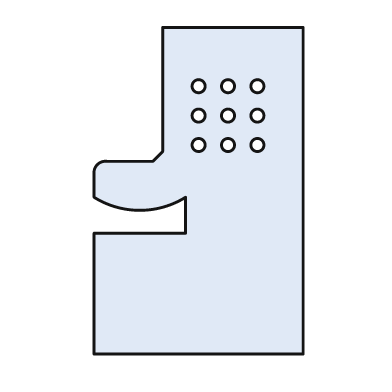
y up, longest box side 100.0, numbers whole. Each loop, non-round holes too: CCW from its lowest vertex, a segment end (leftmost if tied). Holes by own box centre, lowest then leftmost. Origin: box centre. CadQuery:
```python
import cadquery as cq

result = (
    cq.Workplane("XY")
    .moveTo(-32.0, -50.0)
    .lineTo(32.0, -50.0)
    .lineTo(32.0, 50.0)
    .lineTo(-11.0, 50.0)
    .lineTo(-11.0, 12.0)
    .lineTo(-14.0, 9.0)
    .lineTo(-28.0, 9.0)
    .threePointArc((-31.0, 8.0), (-32.0, 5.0))
    .lineTo(-32.0, -2.0)
    .threePointArc((-18.0, -6.0), (-4.0, -2.0))
    .lineTo(-4.0, -13.0)
    .lineTo(-32.0, -13.0)
    .close()
    .moveTo(0.0, 14.0)
    .circle(2.0)
    .moveTo(9.0, 14.0)
    .circle(2.0)
    .moveTo(18.0, 14.0)
    .circle(2.0)
    .moveTo(0.0, 23.0)
    .circle(2.0)
    .moveTo(9.0, 23.0)
    .circle(2.0)
    .moveTo(18.0, 23.0)
    .circle(2.0)
    .moveTo(0.0, 32.0)
    .circle(2.0)
    .moveTo(9.0, 32.0)
    .circle(2.0)
    .moveTo(18.0, 32.0)
    .circle(2.0)
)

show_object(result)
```